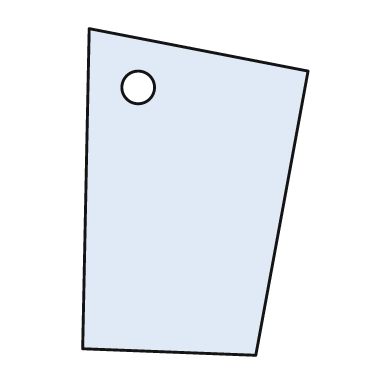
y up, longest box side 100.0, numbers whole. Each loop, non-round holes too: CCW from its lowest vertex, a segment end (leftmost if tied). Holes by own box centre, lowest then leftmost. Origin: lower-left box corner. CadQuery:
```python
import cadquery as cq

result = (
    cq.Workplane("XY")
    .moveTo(53.0, 0.0)
    .lineTo(69.0, 87.0)
    .lineTo(2.0, 100.0)
    .lineTo(0.0, 2.0)
    .close()
    .moveTo(17.0, 82.0)
    .circle(5.0)
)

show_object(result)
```